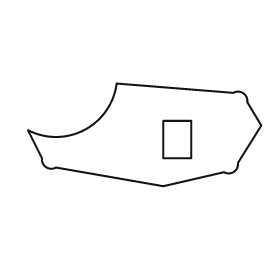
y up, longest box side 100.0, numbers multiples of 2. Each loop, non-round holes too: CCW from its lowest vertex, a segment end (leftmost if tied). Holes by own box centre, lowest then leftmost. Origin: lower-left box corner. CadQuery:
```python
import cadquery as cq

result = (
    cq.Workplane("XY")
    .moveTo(58.0, 0.0)
    .lineTo(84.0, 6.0)
    .threePointArc((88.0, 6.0), (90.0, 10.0))
    .lineTo(100.0, 26.0)
    .lineTo(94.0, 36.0)
    .threePointArc((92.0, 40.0), (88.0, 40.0))
    .lineTo(38.0, 44.0)
    .threePointArc((24.0, 24.0), (0.0, 24.0))
    .lineTo(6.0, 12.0)
    .threePointArc((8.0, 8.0), (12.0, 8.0))
    .close()
    .moveTo(58.0, 12.0)
    .lineTo(70.0, 12.0)
    .lineTo(70.0, 28.0)
    .lineTo(58.0, 28.0)
    .close()
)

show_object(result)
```